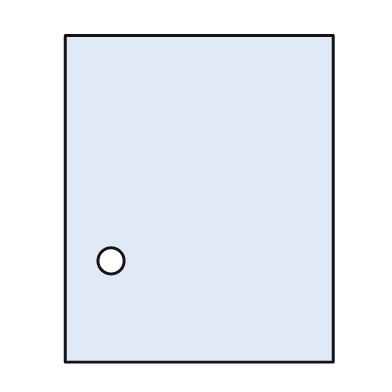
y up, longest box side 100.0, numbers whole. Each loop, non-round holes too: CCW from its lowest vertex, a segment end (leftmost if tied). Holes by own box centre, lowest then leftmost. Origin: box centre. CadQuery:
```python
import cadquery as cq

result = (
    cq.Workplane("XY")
    .moveTo(-41.0, -50.0)
    .lineTo(41.0, -50.0)
    .lineTo(41.0, 50.0)
    .lineTo(-41.0, 50.0)
    .close()
    .moveTo(-27.0, -19.0)
    .circle(4.0)
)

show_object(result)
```